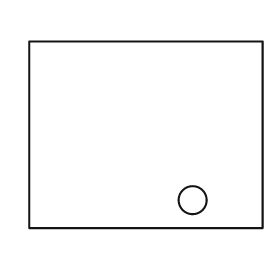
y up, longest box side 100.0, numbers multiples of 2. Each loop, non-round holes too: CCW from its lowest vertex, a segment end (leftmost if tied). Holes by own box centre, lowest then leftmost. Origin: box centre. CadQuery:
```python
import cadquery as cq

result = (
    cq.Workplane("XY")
    .moveTo(-50.0, -40.0)
    .lineTo(50.0, -40.0)
    .lineTo(50.0, 40.0)
    .lineTo(-50.0, 40.0)
    .close()
    .moveTo(20.0, -28.0)
    .circle(6.0)
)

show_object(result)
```